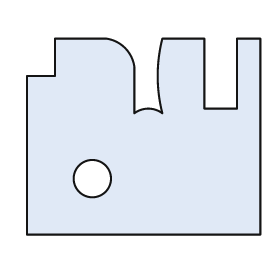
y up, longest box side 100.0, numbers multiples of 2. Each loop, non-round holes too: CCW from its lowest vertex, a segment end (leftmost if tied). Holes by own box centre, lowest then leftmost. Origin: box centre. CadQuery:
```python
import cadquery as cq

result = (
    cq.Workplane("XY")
    .moveTo(-50.0, -42.0)
    .lineTo(50.0, -42.0)
    .lineTo(50.0, 42.0)
    .lineTo(40.0, 42.0)
    .lineTo(40.0, 12.0)
    .lineTo(26.0, 12.0)
    .lineTo(26.0, 42.0)
    .lineTo(8.0, 42.0)
    .threePointArc((6.0, 26.0), (8.0, 10.0))
    .threePointArc((2.0, 12.0), (-4.0, 10.0))
    .lineTo(-4.0, 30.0)
    .threePointArc((-8.0, 38.0), (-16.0, 42.0))
    .lineTo(-38.0, 42.0)
    .lineTo(-38.0, 26.0)
    .lineTo(-50.0, 26.0)
    .close()
    .moveTo(-22.0, -18.0)
    .circle(8.0)
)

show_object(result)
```